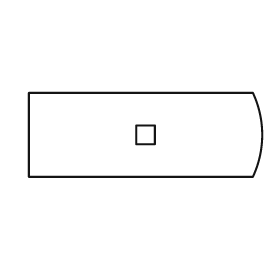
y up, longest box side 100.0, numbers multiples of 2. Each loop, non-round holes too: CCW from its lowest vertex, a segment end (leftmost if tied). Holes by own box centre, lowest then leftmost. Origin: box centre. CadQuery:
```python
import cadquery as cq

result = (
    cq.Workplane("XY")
    .moveTo(-50.0, -18.0)
    .lineTo(46.0, -18.0)
    .threePointArc((50.0, 0.0), (46.0, 18.0))
    .lineTo(-50.0, 18.0)
    .close()
    .moveTo(-4.0, -4.0)
    .lineTo(4.0, -4.0)
    .lineTo(4.0, 4.0)
    .lineTo(-4.0, 4.0)
    .close()
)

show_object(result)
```